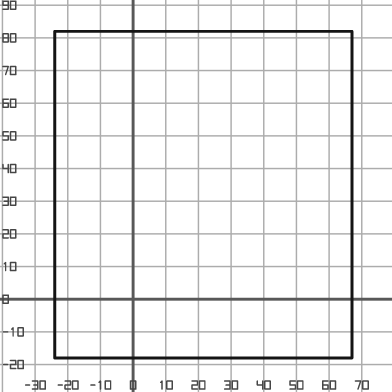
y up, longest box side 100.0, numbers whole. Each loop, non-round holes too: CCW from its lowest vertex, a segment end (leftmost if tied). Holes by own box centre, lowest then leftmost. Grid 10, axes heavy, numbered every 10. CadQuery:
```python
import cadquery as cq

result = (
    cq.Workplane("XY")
    .moveTo(-24.0, -18.0)
    .lineTo(67.0, -18.0)
    .lineTo(67.0, 82.0)
    .lineTo(-24.0, 82.0)
    .close()
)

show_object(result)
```